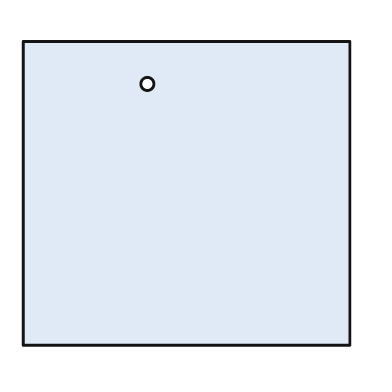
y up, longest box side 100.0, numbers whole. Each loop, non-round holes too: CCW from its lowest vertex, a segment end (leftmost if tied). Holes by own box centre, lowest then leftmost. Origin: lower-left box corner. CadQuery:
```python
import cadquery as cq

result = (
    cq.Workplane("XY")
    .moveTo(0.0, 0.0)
    .lineTo(100.0, 0.0)
    .lineTo(100.0, 93.0)
    .lineTo(0.0, 93.0)
    .close()
    .moveTo(38.0, 80.0)
    .circle(2.0)
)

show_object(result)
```